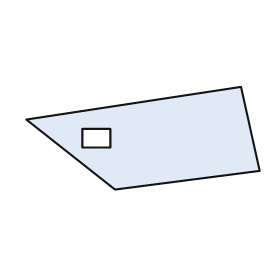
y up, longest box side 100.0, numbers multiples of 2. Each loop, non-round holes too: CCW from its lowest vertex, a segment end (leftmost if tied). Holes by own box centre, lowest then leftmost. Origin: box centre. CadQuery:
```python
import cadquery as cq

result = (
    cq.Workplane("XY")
    .moveTo(-12.0, -22.0)
    .lineTo(50.0, -14.0)
    .lineTo(42.0, 22.0)
    .lineTo(-50.0, 8.0)
    .close()
    .moveTo(-26.0, -4.0)
    .lineTo(-14.0, -4.0)
    .lineTo(-14.0, 4.0)
    .lineTo(-26.0, 4.0)
    .close()
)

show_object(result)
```